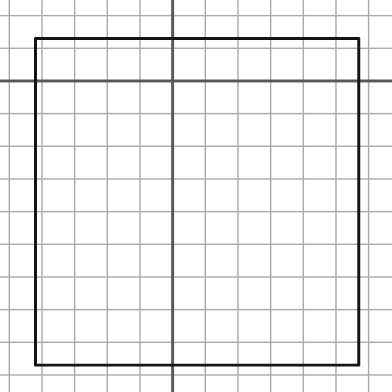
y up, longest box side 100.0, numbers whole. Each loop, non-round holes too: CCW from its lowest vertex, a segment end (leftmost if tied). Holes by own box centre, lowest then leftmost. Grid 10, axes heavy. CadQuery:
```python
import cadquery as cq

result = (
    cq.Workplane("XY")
    .moveTo(-42.0, -87.0)
    .lineTo(57.0, -87.0)
    .lineTo(57.0, 13.0)
    .lineTo(-42.0, 13.0)
    .close()
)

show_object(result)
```